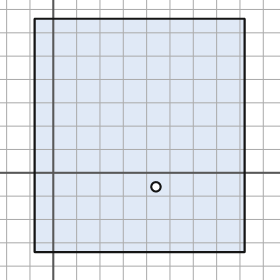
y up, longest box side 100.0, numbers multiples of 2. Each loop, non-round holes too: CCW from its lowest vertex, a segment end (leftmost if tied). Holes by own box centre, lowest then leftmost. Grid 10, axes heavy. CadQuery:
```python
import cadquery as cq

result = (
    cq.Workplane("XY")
    .moveTo(-8.0, -34.0)
    .lineTo(82.0, -34.0)
    .lineTo(82.0, 66.0)
    .lineTo(-8.0, 66.0)
    .close()
    .moveTo(44.0, -6.0)
    .circle(2.0)
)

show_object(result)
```